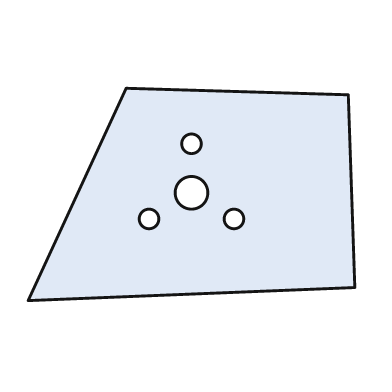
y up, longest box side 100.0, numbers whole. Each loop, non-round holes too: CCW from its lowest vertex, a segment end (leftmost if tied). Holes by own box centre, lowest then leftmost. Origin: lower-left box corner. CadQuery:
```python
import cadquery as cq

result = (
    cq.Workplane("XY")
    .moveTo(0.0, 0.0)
    .lineTo(100.0, 4.0)
    .lineTo(98.0, 63.0)
    .lineTo(30.0, 65.0)
    .close()
    .moveTo(37.0, 25.0)
    .circle(3.0)
    .moveTo(63.0, 25.0)
    .circle(3.0)
    .moveTo(50.0, 33.0)
    .circle(5.0)
    .moveTo(50.0, 48.0)
    .circle(3.0)
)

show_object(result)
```